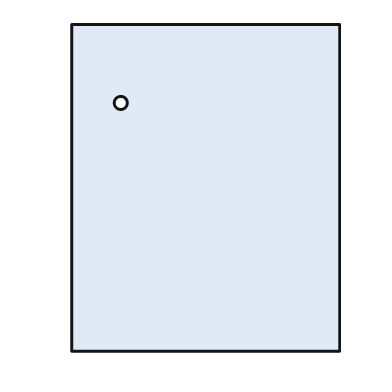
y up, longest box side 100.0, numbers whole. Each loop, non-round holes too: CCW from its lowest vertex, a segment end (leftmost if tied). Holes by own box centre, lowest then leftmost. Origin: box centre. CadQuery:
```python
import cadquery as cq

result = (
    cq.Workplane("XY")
    .moveTo(-41.0, -50.0)
    .lineTo(41.0, -50.0)
    .lineTo(41.0, 50.0)
    .lineTo(-41.0, 50.0)
    .close()
    .moveTo(-26.0, 26.0)
    .circle(2.0)
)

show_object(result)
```